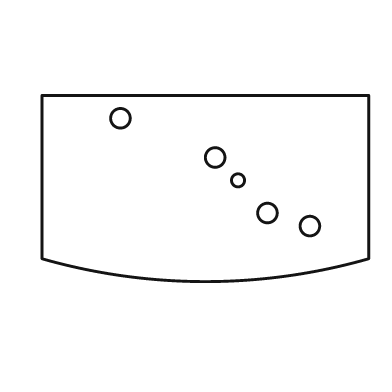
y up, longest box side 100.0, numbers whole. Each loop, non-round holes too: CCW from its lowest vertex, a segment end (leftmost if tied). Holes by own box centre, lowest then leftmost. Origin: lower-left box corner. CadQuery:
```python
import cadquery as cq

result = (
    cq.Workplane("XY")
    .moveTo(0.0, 7.0)
    .threePointArc((50.0, 0.0), (100.0, 7.0))
    .lineTo(100.0, 57.0)
    .lineTo(0.0, 57.0)
    .close()
    .moveTo(82.0, 17.0)
    .circle(3.0)
    .moveTo(69.0, 21.0)
    .circle(3.0)
    .moveTo(60.0, 31.0)
    .circle(2.0)
    .moveTo(53.0, 38.0)
    .circle(3.0)
    .moveTo(24.0, 50.0)
    .circle(3.0)
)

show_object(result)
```